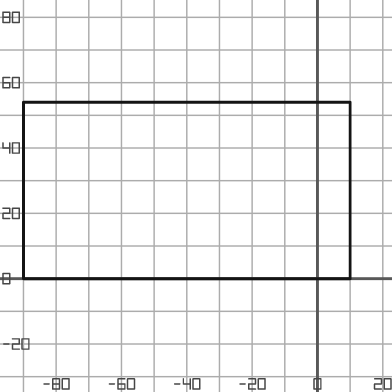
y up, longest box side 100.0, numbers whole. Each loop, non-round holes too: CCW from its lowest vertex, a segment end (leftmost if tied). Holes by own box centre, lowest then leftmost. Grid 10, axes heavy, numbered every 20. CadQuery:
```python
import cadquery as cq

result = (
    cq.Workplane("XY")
    .moveTo(-90.0, 0.0)
    .lineTo(10.0, 0.0)
    .lineTo(10.0, 54.0)
    .lineTo(-90.0, 54.0)
    .close()
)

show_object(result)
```